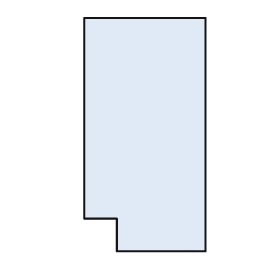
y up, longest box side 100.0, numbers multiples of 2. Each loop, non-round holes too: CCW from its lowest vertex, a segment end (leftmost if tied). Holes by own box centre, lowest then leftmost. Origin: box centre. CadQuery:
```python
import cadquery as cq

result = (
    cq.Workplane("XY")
    .moveTo(-12.0, -50.0)
    .lineTo(26.0, -50.0)
    .lineTo(26.0, 50.0)
    .lineTo(-26.0, 50.0)
    .lineTo(-26.0, -36.0)
    .lineTo(-12.0, -36.0)
    .close()
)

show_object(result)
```